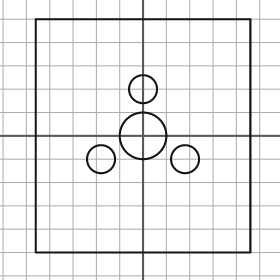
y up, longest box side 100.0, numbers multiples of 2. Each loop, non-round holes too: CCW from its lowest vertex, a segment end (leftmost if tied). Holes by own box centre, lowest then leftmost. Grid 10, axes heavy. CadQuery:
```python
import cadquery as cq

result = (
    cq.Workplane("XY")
    .moveTo(-46.0, -50.0)
    .lineTo(46.0, -50.0)
    .lineTo(46.0, 50.0)
    .lineTo(-46.0, 50.0)
    .close()
    .moveTo(-18.0, -10.0)
    .circle(6.0)
    .moveTo(18.0, -10.0)
    .circle(6.0)
    .moveTo(0.0, 0.0)
    .circle(10.0)
    .moveTo(0.0, 20.0)
    .circle(6.0)
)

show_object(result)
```